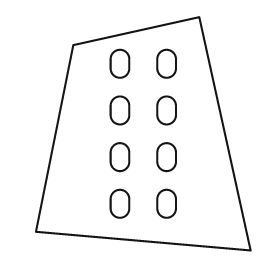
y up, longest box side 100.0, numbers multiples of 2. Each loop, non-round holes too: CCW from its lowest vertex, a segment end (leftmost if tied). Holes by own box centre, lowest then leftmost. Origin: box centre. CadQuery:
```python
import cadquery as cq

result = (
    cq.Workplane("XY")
    .moveTo(46.0, -50.0)
    .lineTo(24.0, 50.0)
    .lineTo(-30.0, 38.0)
    .lineTo(-46.0, -42.0)
    .close()
    .moveTo(-14.0, -32.0)
    .threePointArc((-10.0, -36.0), (-6.0, -32.0))
    .lineTo(-6.0, -28.0)
    .threePointArc((-10.0, -24.0), (-14.0, -28.0))
    .close()
    .moveTo(6.0, -32.0)
    .threePointArc((10.0, -36.0), (14.0, -32.0))
    .lineTo(14.0, -28.0)
    .threePointArc((10.0, -24.0), (6.0, -28.0))
    .close()
    .moveTo(-14.0, -12.0)
    .threePointArc((-10.0, -16.0), (-6.0, -12.0))
    .lineTo(-6.0, -8.0)
    .threePointArc((-10.0, -4.0), (-14.0, -8.0))
    .close()
    .moveTo(6.0, -12.0)
    .threePointArc((10.0, -16.0), (14.0, -12.0))
    .lineTo(14.0, -8.0)
    .threePointArc((10.0, -4.0), (6.0, -8.0))
    .close()
    .moveTo(-14.0, 8.0)
    .threePointArc((-10.0, 4.0), (-6.0, 8.0))
    .lineTo(-6.0, 12.0)
    .threePointArc((-10.0, 16.0), (-14.0, 12.0))
    .close()
    .moveTo(6.0, 8.0)
    .threePointArc((10.0, 4.0), (14.0, 8.0))
    .lineTo(14.0, 12.0)
    .threePointArc((10.0, 16.0), (6.0, 12.0))
    .close()
    .moveTo(-14.0, 28.0)
    .threePointArc((-10.0, 24.0), (-6.0, 28.0))
    .lineTo(-6.0, 32.0)
    .threePointArc((-10.0, 36.0), (-14.0, 32.0))
    .close()
    .moveTo(6.0, 28.0)
    .threePointArc((10.0, 24.0), (14.0, 28.0))
    .lineTo(14.0, 32.0)
    .threePointArc((10.0, 36.0), (6.0, 32.0))
    .close()
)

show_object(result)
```